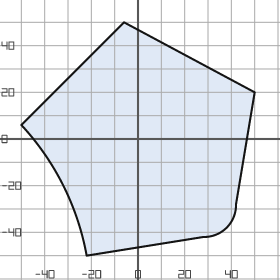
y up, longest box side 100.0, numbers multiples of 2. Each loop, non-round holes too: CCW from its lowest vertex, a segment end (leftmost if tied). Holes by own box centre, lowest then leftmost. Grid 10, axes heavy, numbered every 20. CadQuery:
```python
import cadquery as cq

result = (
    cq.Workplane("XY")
    .moveTo(-22.0, -50.0)
    .lineTo(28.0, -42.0)
    .threePointArc((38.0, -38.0), (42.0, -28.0))
    .lineTo(50.0, 20.0)
    .lineTo(-6.0, 50.0)
    .lineTo(-50.0, 6.0)
    .threePointArc((-32.0, -20.0), (-22.0, -50.0))
    .close()
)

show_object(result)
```